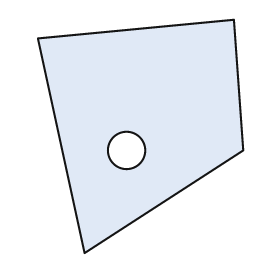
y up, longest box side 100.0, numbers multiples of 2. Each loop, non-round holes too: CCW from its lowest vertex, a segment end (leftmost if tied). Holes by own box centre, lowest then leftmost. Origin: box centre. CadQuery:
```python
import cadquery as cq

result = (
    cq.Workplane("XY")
    .moveTo(-24.0, -50.0)
    .lineTo(44.0, -6.0)
    .lineTo(40.0, 50.0)
    .lineTo(-44.0, 42.0)
    .close()
    .moveTo(-6.0, -6.0)
    .circle(8.0)
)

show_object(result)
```